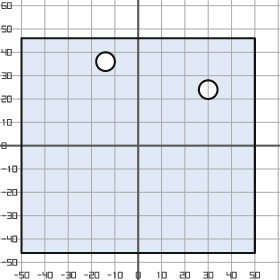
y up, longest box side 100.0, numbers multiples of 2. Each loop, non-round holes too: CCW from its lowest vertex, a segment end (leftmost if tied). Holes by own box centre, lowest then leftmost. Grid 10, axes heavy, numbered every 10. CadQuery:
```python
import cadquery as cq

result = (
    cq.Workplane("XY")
    .moveTo(-50.0, -46.0)
    .lineTo(50.0, -46.0)
    .lineTo(50.0, 46.0)
    .lineTo(-50.0, 46.0)
    .close()
    .moveTo(30.0, 24.0)
    .circle(4.0)
    .moveTo(-14.0, 36.0)
    .circle(4.0)
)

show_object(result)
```